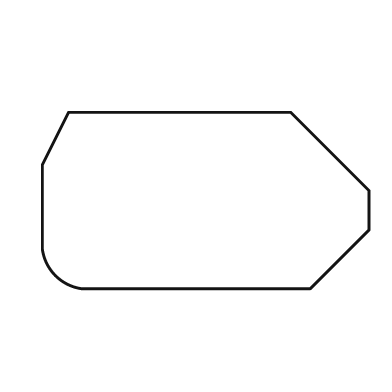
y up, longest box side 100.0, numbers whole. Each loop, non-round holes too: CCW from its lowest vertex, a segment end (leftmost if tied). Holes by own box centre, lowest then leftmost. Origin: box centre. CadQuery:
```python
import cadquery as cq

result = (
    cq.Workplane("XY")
    .moveTo(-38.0, -27.0)
    .lineTo(32.0, -27.0)
    .lineTo(50.0, -9.0)
    .lineTo(50.0, 3.0)
    .lineTo(26.0, 27.0)
    .lineTo(-42.0, 27.0)
    .lineTo(-50.0, 11.0)
    .lineTo(-50.0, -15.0)
    .threePointArc((-46.0, -23.0), (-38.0, -27.0))
    .close()
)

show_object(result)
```